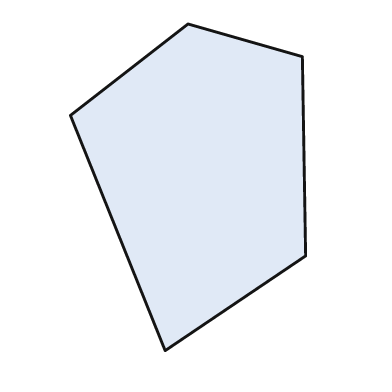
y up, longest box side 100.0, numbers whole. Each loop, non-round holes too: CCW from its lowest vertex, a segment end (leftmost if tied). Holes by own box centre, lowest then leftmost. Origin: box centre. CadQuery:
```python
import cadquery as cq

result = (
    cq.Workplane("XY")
    .moveTo(-7.0, -50.0)
    .lineTo(36.0, -21.0)
    .lineTo(35.0, 40.0)
    .lineTo(0.0, 50.0)
    .lineTo(-36.0, 22.0)
    .close()
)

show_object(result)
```